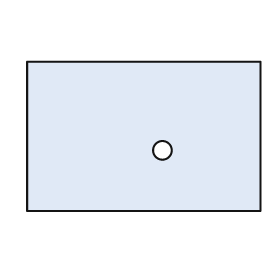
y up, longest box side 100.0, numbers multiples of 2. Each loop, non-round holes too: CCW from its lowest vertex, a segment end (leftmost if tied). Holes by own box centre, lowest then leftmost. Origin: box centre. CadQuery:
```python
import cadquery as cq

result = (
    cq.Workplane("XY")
    .moveTo(-50.0, -32.0)
    .lineTo(50.0, -32.0)
    .lineTo(50.0, 32.0)
    .lineTo(-50.0, 32.0)
    .close()
    .moveTo(8.0, -6.0)
    .circle(4.0)
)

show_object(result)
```